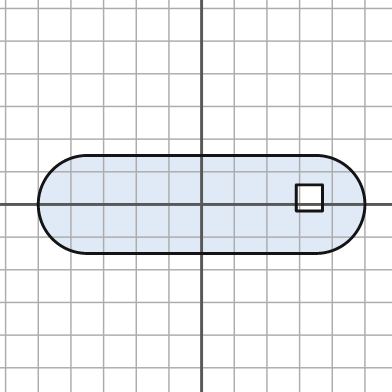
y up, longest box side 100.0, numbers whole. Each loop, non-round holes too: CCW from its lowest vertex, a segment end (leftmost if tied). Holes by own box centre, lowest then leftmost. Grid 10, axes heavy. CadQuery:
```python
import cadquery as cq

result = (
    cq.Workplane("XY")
    .moveTo(-35.0, -15.0)
    .lineTo(35.0, -15.0)
    .threePointArc((50.0, 0.0), (35.0, 15.0))
    .lineTo(-35.0, 15.0)
    .threePointArc((-50.0, 0.0), (-35.0, -15.0))
    .close()
    .moveTo(29.0, -2.0)
    .lineTo(37.0, -2.0)
    .lineTo(37.0, 6.0)
    .lineTo(29.0, 6.0)
    .close()
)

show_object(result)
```